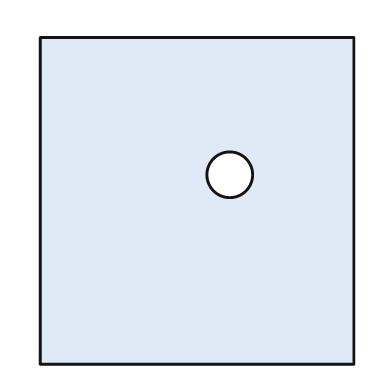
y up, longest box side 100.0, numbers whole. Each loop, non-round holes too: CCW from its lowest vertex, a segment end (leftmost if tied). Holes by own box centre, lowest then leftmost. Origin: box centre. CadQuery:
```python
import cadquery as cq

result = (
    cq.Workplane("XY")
    .moveTo(-48.0, -50.0)
    .lineTo(48.0, -50.0)
    .lineTo(48.0, 50.0)
    .lineTo(-48.0, 50.0)
    .close()
    .moveTo(10.0, 8.0)
    .circle(7.0)
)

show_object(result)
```